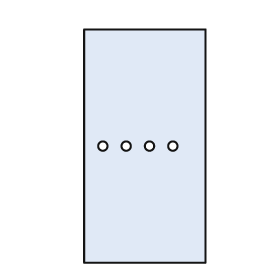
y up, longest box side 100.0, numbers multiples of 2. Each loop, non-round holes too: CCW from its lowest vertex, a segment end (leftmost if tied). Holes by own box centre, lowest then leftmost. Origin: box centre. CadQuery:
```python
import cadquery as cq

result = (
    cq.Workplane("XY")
    .moveTo(-26.0, -50.0)
    .lineTo(26.0, -50.0)
    .lineTo(26.0, 50.0)
    .lineTo(-26.0, 50.0)
    .close()
    .moveTo(-18.0, 0.0)
    .circle(2.0)
    .moveTo(-8.0, 0.0)
    .circle(2.0)
    .moveTo(2.0, 0.0)
    .circle(2.0)
    .moveTo(12.0, 0.0)
    .circle(2.0)
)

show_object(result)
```